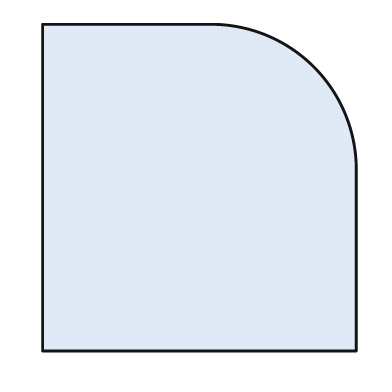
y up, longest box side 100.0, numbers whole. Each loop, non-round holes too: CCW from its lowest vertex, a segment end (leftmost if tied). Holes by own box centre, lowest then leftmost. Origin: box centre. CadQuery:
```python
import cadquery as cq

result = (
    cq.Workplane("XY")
    .moveTo(-48.0, -50.0)
    .lineTo(48.0, -50.0)
    .lineTo(48.0, 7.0)
    .threePointArc((35.0, 37.0), (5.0, 50.0))
    .lineTo(-48.0, 50.0)
    .close()
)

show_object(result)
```